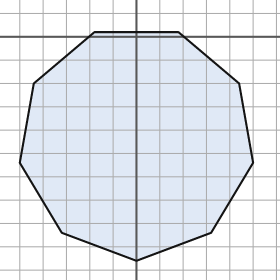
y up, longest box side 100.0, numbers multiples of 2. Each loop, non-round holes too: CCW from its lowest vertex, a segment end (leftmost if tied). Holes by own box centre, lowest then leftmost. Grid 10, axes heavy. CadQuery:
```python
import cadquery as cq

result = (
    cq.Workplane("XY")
    .moveTo(0.0, -96.0)
    .lineTo(32.0, -84.0)
    .lineTo(50.0, -54.0)
    .lineTo(44.0, -20.0)
    .lineTo(18.0, 2.0)
    .lineTo(-18.0, 2.0)
    .lineTo(-44.0, -20.0)
    .lineTo(-50.0, -54.0)
    .lineTo(-32.0, -84.0)
    .close()
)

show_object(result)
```